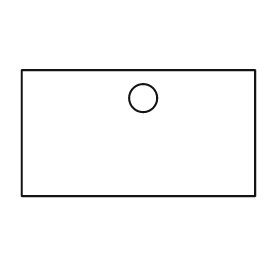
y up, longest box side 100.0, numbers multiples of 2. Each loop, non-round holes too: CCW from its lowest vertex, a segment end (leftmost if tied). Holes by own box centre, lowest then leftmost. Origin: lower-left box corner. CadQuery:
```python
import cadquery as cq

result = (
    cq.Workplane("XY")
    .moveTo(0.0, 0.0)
    .lineTo(100.0, 0.0)
    .lineTo(100.0, 54.0)
    .lineTo(0.0, 54.0)
    .close()
    .moveTo(52.0, 42.0)
    .circle(6.0)
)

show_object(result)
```